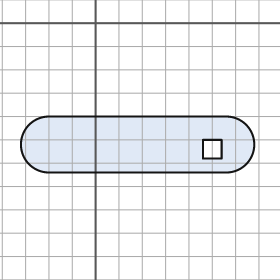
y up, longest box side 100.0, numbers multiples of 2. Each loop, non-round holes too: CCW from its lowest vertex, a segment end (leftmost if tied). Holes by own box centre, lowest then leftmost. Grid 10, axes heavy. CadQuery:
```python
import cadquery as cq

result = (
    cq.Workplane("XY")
    .moveTo(-20.0, -64.0)
    .lineTo(56.0, -64.0)
    .threePointArc((68.0, -52.0), (56.0, -40.0))
    .lineTo(-20.0, -40.0)
    .threePointArc((-32.0, -52.0), (-20.0, -64.0))
    .close()
    .moveTo(46.0, -58.0)
    .lineTo(54.0, -58.0)
    .lineTo(54.0, -50.0)
    .lineTo(46.0, -50.0)
    .close()
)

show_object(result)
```